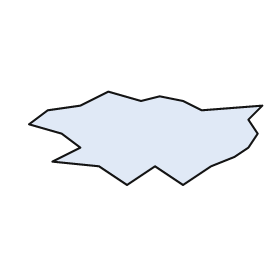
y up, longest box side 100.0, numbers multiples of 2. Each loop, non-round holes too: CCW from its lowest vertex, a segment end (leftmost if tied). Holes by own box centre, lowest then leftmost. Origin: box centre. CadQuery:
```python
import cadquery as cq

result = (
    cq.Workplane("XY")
    .moveTo(-8.0, -20.0)
    .lineTo(4.0, -12.0)
    .lineTo(16.0, -20.0)
    .lineTo(28.0, -12.0)
    .lineTo(38.0, -8.0)
    .lineTo(44.0, -4.0)
    .lineTo(48.0, 2.0)
    .lineTo(44.0, 8.0)
    .lineTo(50.0, 14.0)
    .lineTo(24.0, 12.0)
    .lineTo(16.0, 16.0)
    .lineTo(6.0, 18.0)
    .lineTo(-2.0, 16.0)
    .lineTo(-16.0, 20.0)
    .lineTo(-28.0, 14.0)
    .lineTo(-42.0, 12.0)
    .lineTo(-50.0, 6.0)
    .lineTo(-36.0, 2.0)
    .lineTo(-28.0, -4.0)
    .lineTo(-40.0, -10.0)
    .lineTo(-20.0, -12.0)
    .close()
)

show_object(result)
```